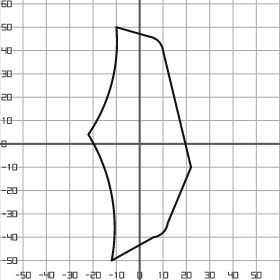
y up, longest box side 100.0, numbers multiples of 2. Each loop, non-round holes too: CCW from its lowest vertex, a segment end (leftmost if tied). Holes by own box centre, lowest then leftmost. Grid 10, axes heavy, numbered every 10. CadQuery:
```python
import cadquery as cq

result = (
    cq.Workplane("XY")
    .moveTo(-12.0, -50.0)
    .lineTo(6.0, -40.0)
    .threePointArc((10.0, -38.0), (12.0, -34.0))
    .lineTo(22.0, -10.0)
    .lineTo(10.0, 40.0)
    .threePointArc((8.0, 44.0), (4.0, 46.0))
    .lineTo(-10.0, 50.0)
    .threePointArc((-12.0, 26.0), (-22.0, 4.0))
    .threePointArc((-12.0, -22.0), (-12.0, -50.0))
    .close()
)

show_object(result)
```